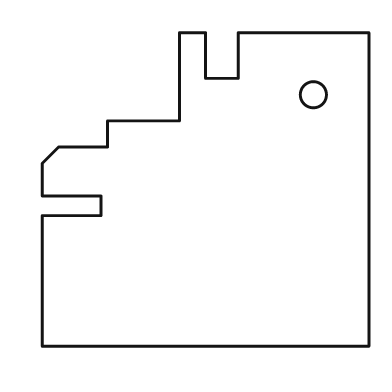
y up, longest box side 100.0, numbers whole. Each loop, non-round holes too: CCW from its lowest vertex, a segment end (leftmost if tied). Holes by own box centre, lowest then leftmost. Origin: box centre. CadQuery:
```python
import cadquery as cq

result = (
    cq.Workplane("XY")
    .moveTo(-50.0, -48.0)
    .lineTo(50.0, -48.0)
    .lineTo(50.0, 48.0)
    .lineTo(10.0, 48.0)
    .lineTo(10.0, 34.0)
    .lineTo(0.0, 34.0)
    .lineTo(0.0, 48.0)
    .lineTo(-8.0, 48.0)
    .lineTo(-8.0, 21.0)
    .lineTo(-30.0, 21.0)
    .lineTo(-30.0, 13.0)
    .lineTo(-45.0, 13.0)
    .lineTo(-50.0, 8.0)
    .lineTo(-50.0, -2.0)
    .lineTo(-32.0, -2.0)
    .lineTo(-32.0, -8.0)
    .lineTo(-50.0, -8.0)
    .close()
    .moveTo(33.0, 29.0)
    .circle(4.0)
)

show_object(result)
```